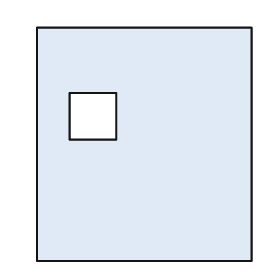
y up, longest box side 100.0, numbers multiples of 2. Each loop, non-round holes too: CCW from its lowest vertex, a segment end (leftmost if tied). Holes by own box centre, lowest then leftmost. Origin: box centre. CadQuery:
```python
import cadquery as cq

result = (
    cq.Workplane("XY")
    .moveTo(-46.0, -50.0)
    .lineTo(46.0, -50.0)
    .lineTo(46.0, 50.0)
    .lineTo(-46.0, 50.0)
    .close()
    .moveTo(-32.0, 2.0)
    .lineTo(-12.0, 2.0)
    .lineTo(-12.0, 22.0)
    .lineTo(-32.0, 22.0)
    .close()
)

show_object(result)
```